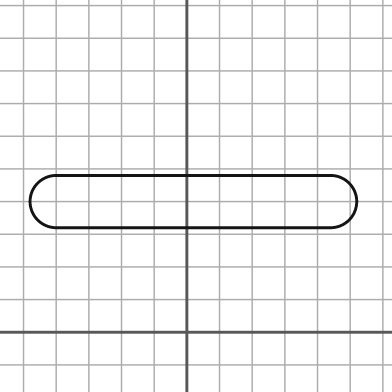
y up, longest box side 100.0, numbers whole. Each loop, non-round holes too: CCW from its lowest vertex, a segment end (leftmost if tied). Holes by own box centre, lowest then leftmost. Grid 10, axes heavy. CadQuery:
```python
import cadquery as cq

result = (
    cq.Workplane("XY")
    .moveTo(-40.0, 32.0)
    .lineTo(44.0, 32.0)
    .threePointArc((52.0, 40.0), (44.0, 48.0))
    .lineTo(-40.0, 48.0)
    .threePointArc((-48.0, 40.0), (-40.0, 32.0))
    .close()
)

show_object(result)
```